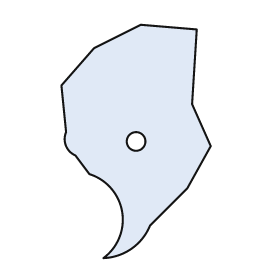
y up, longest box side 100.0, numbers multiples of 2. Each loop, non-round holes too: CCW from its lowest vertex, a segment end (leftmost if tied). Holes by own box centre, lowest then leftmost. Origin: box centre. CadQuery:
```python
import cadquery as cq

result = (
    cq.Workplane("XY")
    .moveTo(-14.0, -50.0)
    .threePointArc((-2.0, -46.0), (6.0, -36.0))
    .lineTo(22.0, -20.0)
    .lineTo(32.0, -2.0)
    .lineTo(24.0, 16.0)
    .lineTo(26.0, 48.0)
    .lineTo(2.0, 50.0)
    .lineTo(-18.0, 40.0)
    .lineTo(-32.0, 24.0)
    .lineTo(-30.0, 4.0)
    .threePointArc((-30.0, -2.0), (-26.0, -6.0))
    .lineTo(-20.0, -14.0)
    .threePointArc((-6.0, -30.0), (-14.0, -50.0))
    .close()
    .moveTo(0.0, 0.0)
    .circle(4.0)
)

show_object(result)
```